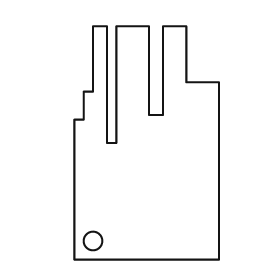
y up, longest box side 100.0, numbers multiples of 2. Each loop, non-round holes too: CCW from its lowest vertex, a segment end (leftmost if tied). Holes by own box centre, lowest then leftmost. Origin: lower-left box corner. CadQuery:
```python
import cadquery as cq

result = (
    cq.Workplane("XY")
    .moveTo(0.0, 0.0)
    .lineTo(62.0, 0.0)
    .lineTo(62.0, 76.0)
    .lineTo(48.0, 76.0)
    .lineTo(48.0, 100.0)
    .lineTo(38.0, 100.0)
    .lineTo(38.0, 62.0)
    .lineTo(32.0, 62.0)
    .lineTo(32.0, 100.0)
    .lineTo(18.0, 100.0)
    .lineTo(18.0, 50.0)
    .lineTo(14.0, 50.0)
    .lineTo(14.0, 100.0)
    .lineTo(8.0, 100.0)
    .lineTo(8.0, 72.0)
    .lineTo(4.0, 72.0)
    .lineTo(4.0, 60.0)
    .lineTo(0.0, 60.0)
    .close()
    .moveTo(8.0, 8.0)
    .circle(4.0)
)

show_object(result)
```